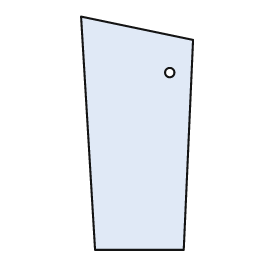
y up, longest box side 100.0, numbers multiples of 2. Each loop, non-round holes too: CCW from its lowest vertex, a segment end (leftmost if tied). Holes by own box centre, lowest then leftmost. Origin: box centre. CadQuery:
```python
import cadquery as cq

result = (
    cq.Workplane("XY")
    .moveTo(-18.0, -50.0)
    .lineTo(20.0, -50.0)
    .lineTo(24.0, 40.0)
    .lineTo(-24.0, 50.0)
    .close()
    .moveTo(14.0, 26.0)
    .circle(2.0)
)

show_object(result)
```